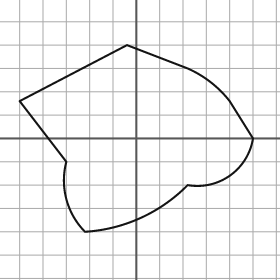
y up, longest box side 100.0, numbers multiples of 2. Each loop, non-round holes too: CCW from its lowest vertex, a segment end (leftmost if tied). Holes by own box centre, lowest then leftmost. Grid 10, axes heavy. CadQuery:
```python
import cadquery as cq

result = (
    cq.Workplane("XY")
    .moveTo(-22.0, -40.0)
    .threePointArc((2.0, -34.0), (22.0, -20.0))
    .threePointArc((40.0, -16.0), (50.0, 0.0))
    .lineTo(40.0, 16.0)
    .threePointArc((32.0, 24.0), (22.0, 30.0))
    .lineTo(-4.0, 40.0)
    .lineTo(-50.0, 16.0)
    .lineTo(-30.0, -10.0)
    .threePointArc((-30.0, -26.0), (-22.0, -40.0))
    .close()
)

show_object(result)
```